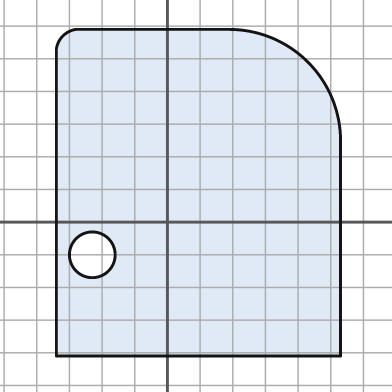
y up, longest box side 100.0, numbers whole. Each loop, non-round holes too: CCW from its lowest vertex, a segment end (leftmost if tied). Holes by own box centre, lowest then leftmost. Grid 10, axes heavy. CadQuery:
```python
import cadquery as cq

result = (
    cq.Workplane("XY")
    .moveTo(-34.0, -41.0)
    .lineTo(53.0, -41.0)
    .lineTo(53.0, 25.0)
    .threePointArc((43.0, 49.0), (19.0, 59.0))
    .lineTo(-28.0, 59.0)
    .threePointArc((-32.0, 57.0), (-34.0, 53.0))
    .close()
    .moveTo(-23.0, -10.0)
    .circle(7.0)
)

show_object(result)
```